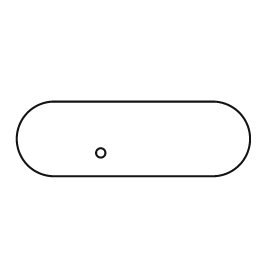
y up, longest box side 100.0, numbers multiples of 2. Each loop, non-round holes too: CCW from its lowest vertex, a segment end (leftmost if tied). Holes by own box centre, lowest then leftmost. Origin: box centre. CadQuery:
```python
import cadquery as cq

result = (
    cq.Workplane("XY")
    .moveTo(-34.0, -16.0)
    .lineTo(34.0, -16.0)
    .threePointArc((50.0, 0.0), (34.0, 16.0))
    .lineTo(-34.0, 16.0)
    .threePointArc((-50.0, 0.0), (-34.0, -16.0))
    .close()
    .moveTo(-14.0, -6.0)
    .circle(2.0)
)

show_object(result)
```